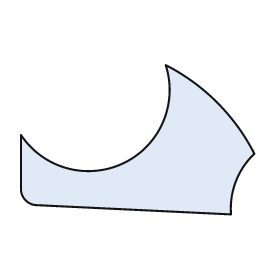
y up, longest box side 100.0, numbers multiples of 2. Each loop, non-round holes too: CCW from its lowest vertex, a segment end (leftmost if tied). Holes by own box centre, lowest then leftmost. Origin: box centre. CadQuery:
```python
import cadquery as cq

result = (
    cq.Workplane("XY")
    .moveTo(40.0, -32.0)
    .threePointArc((42.0, -18.0), (50.0, -6.0))
    .threePointArc((34.0, 16.0), (12.0, 32.0))
    .threePointArc((-6.0, -10.0), (-50.0, 2.0))
    .lineTo(-50.0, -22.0)
    .threePointArc((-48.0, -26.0), (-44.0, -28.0))
    .close()
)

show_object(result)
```